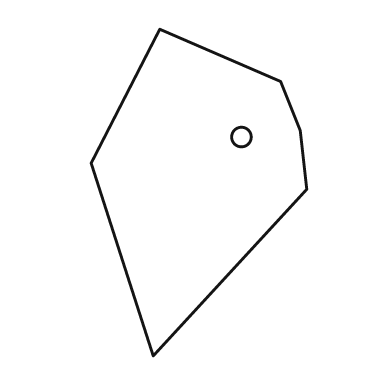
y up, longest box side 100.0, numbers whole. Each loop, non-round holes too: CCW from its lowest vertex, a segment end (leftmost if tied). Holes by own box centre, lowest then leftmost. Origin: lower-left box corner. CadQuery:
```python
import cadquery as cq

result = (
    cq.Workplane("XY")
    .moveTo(19.0, 0.0)
    .lineTo(66.0, 51.0)
    .lineTo(64.0, 69.0)
    .lineTo(58.0, 84.0)
    .lineTo(21.0, 100.0)
    .lineTo(0.0, 59.0)
    .close()
    .moveTo(46.0, 67.0)
    .circle(3.0)
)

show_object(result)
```